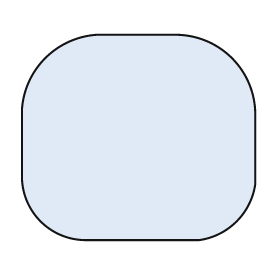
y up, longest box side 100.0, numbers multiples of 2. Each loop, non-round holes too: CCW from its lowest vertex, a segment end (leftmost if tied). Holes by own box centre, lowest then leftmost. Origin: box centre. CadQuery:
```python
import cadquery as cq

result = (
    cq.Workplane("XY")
    .moveTo(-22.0, -44.0)
    .lineTo(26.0, -44.0)
    .threePointArc((42.0, -36.0), (50.0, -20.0))
    .lineTo(50.0, 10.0)
    .threePointArc((40.0, 34.0), (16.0, 44.0))
    .lineTo(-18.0, 44.0)
    .threePointArc((-40.0, 34.0), (-50.0, 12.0))
    .lineTo(-50.0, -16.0)
    .threePointArc((-42.0, -36.0), (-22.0, -44.0))
    .close()
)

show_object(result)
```